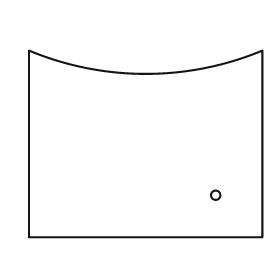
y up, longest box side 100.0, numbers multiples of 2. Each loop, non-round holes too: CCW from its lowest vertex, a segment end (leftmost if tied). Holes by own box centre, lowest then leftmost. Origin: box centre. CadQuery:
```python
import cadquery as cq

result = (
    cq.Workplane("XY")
    .moveTo(-50.0, -40.0)
    .lineTo(50.0, -40.0)
    .lineTo(50.0, 40.0)
    .threePointArc((0.0, 30.0), (-50.0, 40.0))
    .close()
    .moveTo(30.0, -22.0)
    .circle(2.0)
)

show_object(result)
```